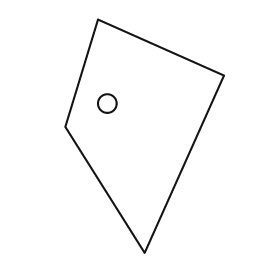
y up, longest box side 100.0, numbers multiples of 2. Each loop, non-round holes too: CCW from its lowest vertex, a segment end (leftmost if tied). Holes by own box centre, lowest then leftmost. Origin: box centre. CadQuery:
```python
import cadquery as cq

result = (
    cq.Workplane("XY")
    .moveTo(0.0, -50.0)
    .lineTo(34.0, 26.0)
    .lineTo(-20.0, 50.0)
    .lineTo(-34.0, 4.0)
    .close()
    .moveTo(-16.0, 14.0)
    .circle(4.0)
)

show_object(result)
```